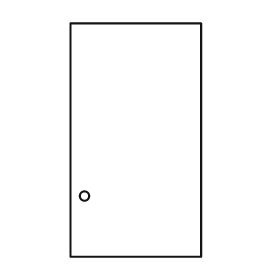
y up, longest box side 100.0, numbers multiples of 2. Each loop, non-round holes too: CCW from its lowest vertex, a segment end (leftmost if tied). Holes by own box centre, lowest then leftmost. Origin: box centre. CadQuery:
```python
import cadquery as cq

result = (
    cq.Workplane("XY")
    .moveTo(-28.0, -50.0)
    .lineTo(28.0, -50.0)
    .lineTo(28.0, 50.0)
    .lineTo(-28.0, 50.0)
    .close()
    .moveTo(-22.0, -24.0)
    .circle(2.0)
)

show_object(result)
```